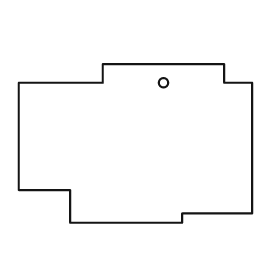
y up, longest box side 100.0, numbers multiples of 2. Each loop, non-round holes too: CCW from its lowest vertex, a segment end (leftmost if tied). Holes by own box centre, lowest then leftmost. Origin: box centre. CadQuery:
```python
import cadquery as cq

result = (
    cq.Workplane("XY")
    .moveTo(-28.0, -34.0)
    .lineTo(20.0, -34.0)
    .lineTo(20.0, -30.0)
    .lineTo(50.0, -30.0)
    .lineTo(50.0, 26.0)
    .lineTo(38.0, 26.0)
    .lineTo(38.0, 34.0)
    .lineTo(-14.0, 34.0)
    .lineTo(-14.0, 26.0)
    .lineTo(-50.0, 26.0)
    .lineTo(-50.0, -20.0)
    .lineTo(-28.0, -20.0)
    .close()
    .moveTo(12.0, 26.0)
    .circle(2.0)
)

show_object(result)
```